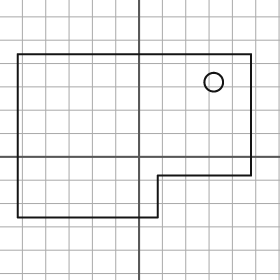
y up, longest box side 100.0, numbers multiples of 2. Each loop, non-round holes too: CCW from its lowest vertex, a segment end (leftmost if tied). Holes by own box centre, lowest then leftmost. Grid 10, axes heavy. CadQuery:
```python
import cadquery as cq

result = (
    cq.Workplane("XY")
    .moveTo(-52.0, -26.0)
    .lineTo(8.0, -26.0)
    .lineTo(8.0, -8.0)
    .lineTo(48.0, -8.0)
    .lineTo(48.0, 44.0)
    .lineTo(-52.0, 44.0)
    .close()
    .moveTo(32.0, 32.0)
    .circle(4.0)
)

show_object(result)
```